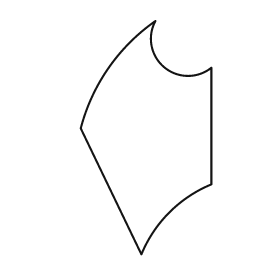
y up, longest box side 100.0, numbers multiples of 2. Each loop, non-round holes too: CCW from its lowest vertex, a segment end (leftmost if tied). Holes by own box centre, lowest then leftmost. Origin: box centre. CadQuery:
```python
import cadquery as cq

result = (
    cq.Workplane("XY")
    .moveTo(-2.0, -50.0)
    .threePointArc((10.0, -32.0), (28.0, -20.0))
    .lineTo(28.0, 30.0)
    .threePointArc((8.0, 30.0), (4.0, 50.0))
    .threePointArc((-16.0, 30.0), (-28.0, 4.0))
    .close()
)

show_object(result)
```